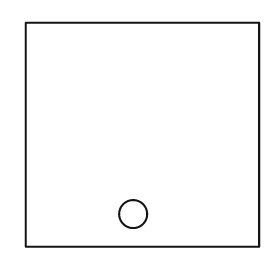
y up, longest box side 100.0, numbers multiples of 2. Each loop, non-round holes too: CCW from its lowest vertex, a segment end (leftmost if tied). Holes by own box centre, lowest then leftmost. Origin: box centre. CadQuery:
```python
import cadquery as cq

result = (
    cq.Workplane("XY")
    .moveTo(-50.0, -48.0)
    .lineTo(50.0, -48.0)
    .lineTo(50.0, 48.0)
    .lineTo(-50.0, 48.0)
    .close()
    .moveTo(-4.0, -34.0)
    .circle(6.0)
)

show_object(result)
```